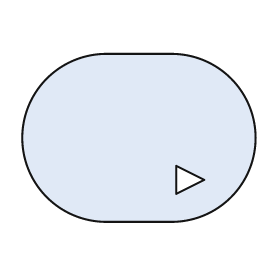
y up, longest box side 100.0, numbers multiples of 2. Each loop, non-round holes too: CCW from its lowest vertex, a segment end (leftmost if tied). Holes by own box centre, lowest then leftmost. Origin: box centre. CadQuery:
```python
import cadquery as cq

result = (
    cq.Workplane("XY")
    .moveTo(-14.0, -36.0)
    .lineTo(14.0, -36.0)
    .threePointArc((50.0, 0.0), (14.0, 36.0))
    .lineTo(-14.0, 36.0)
    .threePointArc((-50.0, 0.0), (-14.0, -36.0))
    .close()
    .moveTo(16.0, -24.0)
    .lineTo(28.0, -18.0)
    .lineTo(16.0, -12.0)
    .close()
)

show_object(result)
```